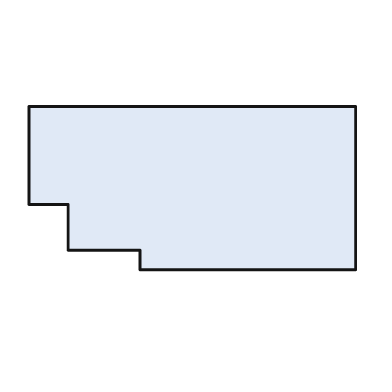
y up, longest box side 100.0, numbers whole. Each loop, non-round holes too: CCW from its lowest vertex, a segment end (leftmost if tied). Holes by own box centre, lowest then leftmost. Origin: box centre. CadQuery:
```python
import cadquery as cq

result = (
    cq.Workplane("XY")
    .moveTo(-16.0, -25.0)
    .lineTo(50.0, -25.0)
    .lineTo(50.0, 25.0)
    .lineTo(-50.0, 25.0)
    .lineTo(-50.0, -5.0)
    .lineTo(-38.0, -5.0)
    .lineTo(-38.0, -19.0)
    .lineTo(-16.0, -19.0)
    .close()
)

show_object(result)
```